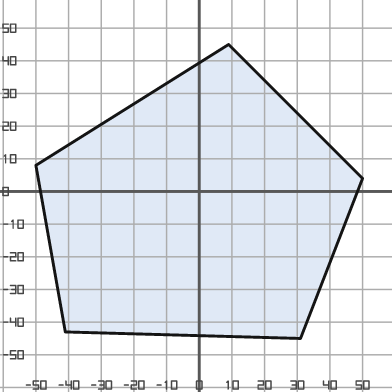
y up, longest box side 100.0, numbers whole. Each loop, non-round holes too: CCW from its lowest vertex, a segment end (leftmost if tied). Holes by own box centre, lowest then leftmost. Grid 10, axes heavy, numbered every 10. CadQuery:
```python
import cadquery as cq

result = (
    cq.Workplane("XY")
    .moveTo(31.0, -45.0)
    .lineTo(50.0, 4.0)
    .lineTo(9.0, 45.0)
    .lineTo(-50.0, 8.0)
    .lineTo(-41.0, -43.0)
    .close()
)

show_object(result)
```